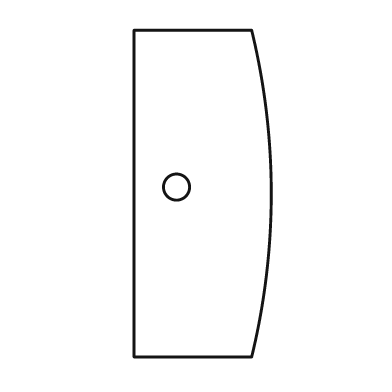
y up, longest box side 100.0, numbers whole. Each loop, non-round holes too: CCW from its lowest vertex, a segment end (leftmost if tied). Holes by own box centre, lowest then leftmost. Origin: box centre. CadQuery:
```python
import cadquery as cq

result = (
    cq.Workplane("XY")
    .moveTo(-21.0, -50.0)
    .lineTo(15.0, -50.0)
    .threePointArc((21.0, 0.0), (15.0, 50.0))
    .lineTo(-21.0, 50.0)
    .close()
    .moveTo(-8.0, 2.0)
    .circle(4.0)
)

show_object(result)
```